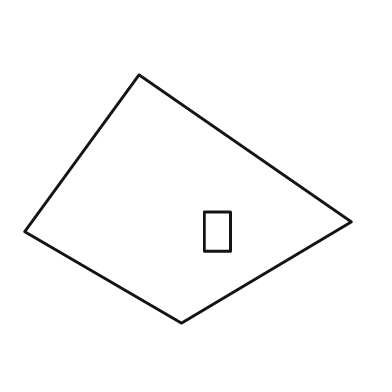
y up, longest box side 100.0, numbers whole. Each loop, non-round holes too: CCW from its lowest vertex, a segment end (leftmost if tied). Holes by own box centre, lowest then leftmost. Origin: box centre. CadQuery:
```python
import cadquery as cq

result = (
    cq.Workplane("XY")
    .moveTo(-2.0, -38.0)
    .lineTo(50.0, -7.0)
    .lineTo(-15.0, 38.0)
    .lineTo(-50.0, -10.0)
    .close()
    .moveTo(5.0, -16.0)
    .lineTo(13.0, -16.0)
    .lineTo(13.0, -4.0)
    .lineTo(5.0, -4.0)
    .close()
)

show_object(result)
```